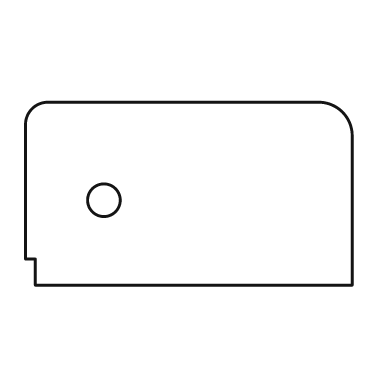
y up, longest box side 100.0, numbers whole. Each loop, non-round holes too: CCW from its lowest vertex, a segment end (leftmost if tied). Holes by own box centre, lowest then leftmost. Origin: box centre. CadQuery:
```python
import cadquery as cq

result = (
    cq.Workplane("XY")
    .moveTo(-47.0, -28.0)
    .lineTo(50.0, -28.0)
    .lineTo(50.0, 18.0)
    .threePointArc((47.0, 25.0), (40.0, 28.0))
    .lineTo(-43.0, 28.0)
    .threePointArc((-48.0, 26.0), (-50.0, 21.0))
    .lineTo(-50.0, -20.0)
    .lineTo(-47.0, -20.0)
    .close()
    .moveTo(-26.0, -2.0)
    .circle(5.0)
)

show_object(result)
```